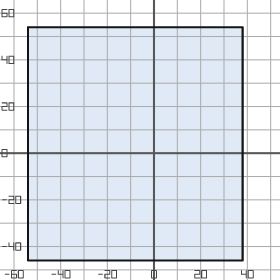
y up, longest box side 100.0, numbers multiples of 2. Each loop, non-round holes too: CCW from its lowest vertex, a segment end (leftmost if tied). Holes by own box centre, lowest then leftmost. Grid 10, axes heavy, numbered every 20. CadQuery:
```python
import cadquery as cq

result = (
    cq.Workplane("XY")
    .moveTo(-54.0, -46.0)
    .lineTo(38.0, -46.0)
    .lineTo(38.0, 54.0)
    .lineTo(-54.0, 54.0)
    .close()
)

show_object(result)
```